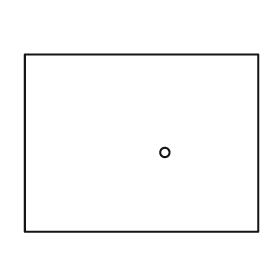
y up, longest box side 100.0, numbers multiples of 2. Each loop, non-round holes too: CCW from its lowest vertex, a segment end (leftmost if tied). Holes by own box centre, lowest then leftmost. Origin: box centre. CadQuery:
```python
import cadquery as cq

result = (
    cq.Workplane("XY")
    .moveTo(-50.0, -38.0)
    .lineTo(50.0, -38.0)
    .lineTo(50.0, 38.0)
    .lineTo(-50.0, 38.0)
    .close()
    .moveTo(10.0, -4.0)
    .circle(2.0)
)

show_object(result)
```